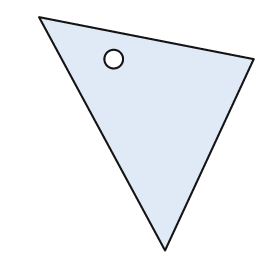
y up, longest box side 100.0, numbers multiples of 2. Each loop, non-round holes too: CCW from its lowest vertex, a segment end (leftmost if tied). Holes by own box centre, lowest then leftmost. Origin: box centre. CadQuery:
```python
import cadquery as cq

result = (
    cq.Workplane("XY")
    .moveTo(8.0, -50.0)
    .lineTo(46.0, 32.0)
    .lineTo(-46.0, 50.0)
    .close()
    .moveTo(-14.0, 32.0)
    .circle(4.0)
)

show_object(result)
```